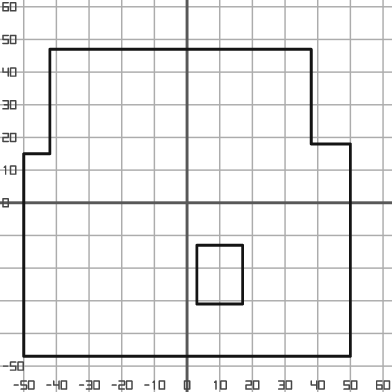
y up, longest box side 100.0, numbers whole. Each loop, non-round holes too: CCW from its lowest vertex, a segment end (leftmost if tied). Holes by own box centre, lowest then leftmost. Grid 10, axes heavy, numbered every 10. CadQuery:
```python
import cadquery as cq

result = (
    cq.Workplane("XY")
    .moveTo(-50.0, -47.0)
    .lineTo(50.0, -47.0)
    .lineTo(50.0, 18.0)
    .lineTo(38.0, 18.0)
    .lineTo(38.0, 47.0)
    .lineTo(-42.0, 47.0)
    .lineTo(-42.0, 15.0)
    .lineTo(-50.0, 15.0)
    .close()
    .moveTo(3.0, -31.0)
    .lineTo(17.0, -31.0)
    .lineTo(17.0, -13.0)
    .lineTo(3.0, -13.0)
    .close()
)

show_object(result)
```